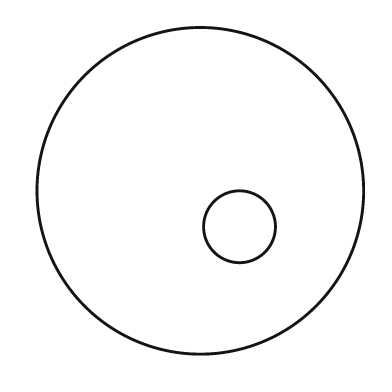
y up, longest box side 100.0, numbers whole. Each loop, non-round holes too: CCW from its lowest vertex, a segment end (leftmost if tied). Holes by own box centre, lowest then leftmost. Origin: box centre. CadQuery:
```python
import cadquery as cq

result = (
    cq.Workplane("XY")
    .moveTo(0.0, 0.0)
    .circle(50.0)
    .moveTo(12.0, -11.0)
    .circle(11.0)
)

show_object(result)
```